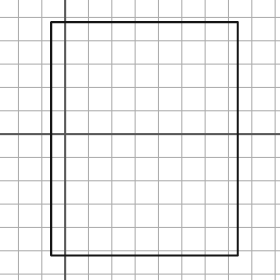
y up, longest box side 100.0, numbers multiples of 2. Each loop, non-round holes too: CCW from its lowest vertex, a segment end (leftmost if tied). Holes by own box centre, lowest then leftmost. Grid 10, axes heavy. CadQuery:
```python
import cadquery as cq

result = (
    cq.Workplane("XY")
    .moveTo(-6.0, -52.0)
    .lineTo(74.0, -52.0)
    .lineTo(74.0, 48.0)
    .lineTo(-6.0, 48.0)
    .close()
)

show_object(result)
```